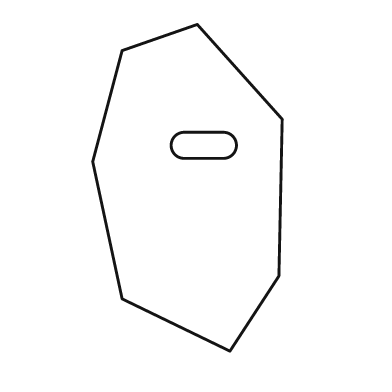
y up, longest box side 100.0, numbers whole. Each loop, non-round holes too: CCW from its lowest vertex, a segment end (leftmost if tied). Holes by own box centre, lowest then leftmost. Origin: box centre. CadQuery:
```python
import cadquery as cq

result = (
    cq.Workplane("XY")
    .moveTo(13.0, -50.0)
    .lineTo(28.0, -27.0)
    .lineTo(29.0, 21.0)
    .lineTo(3.0, 50.0)
    .lineTo(-20.0, 42.0)
    .lineTo(-29.0, 8.0)
    .lineTo(-20.0, -34.0)
    .close()
    .moveTo(-1.0, 9.0)
    .lineTo(11.0, 9.0)
    .threePointArc((15.0, 13.0), (11.0, 17.0))
    .lineTo(-1.0, 17.0)
    .threePointArc((-5.0, 13.0), (-1.0, 9.0))
    .close()
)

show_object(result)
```